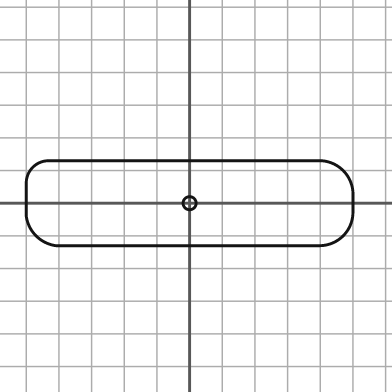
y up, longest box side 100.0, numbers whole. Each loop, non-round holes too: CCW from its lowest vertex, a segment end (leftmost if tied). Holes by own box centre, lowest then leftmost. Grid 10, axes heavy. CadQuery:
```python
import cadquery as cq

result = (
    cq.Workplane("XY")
    .moveTo(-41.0, -13.0)
    .lineTo(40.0, -13.0)
    .threePointArc((47.0, -10.0), (50.0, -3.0))
    .lineTo(50.0, 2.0)
    .threePointArc((47.0, 10.0), (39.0, 13.0))
    .lineTo(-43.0, 13.0)
    .threePointArc((-48.0, 11.0), (-50.0, 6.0))
    .lineTo(-50.0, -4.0)
    .threePointArc((-47.0, -10.0), (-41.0, -13.0))
    .close()
    .moveTo(0.0, 0.0)
    .circle(2.0)
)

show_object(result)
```